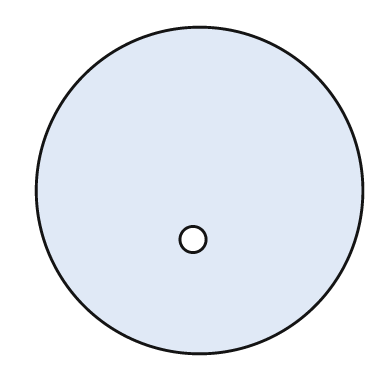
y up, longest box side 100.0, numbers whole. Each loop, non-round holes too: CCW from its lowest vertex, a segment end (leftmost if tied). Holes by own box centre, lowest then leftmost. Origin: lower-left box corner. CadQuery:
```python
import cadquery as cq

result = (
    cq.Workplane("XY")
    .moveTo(50.0, 50.0)
    .circle(50.0)
    .moveTo(48.0, 35.0)
    .circle(4.0)
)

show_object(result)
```